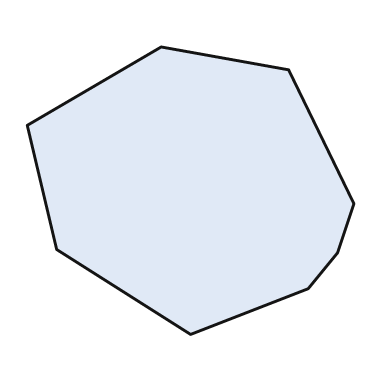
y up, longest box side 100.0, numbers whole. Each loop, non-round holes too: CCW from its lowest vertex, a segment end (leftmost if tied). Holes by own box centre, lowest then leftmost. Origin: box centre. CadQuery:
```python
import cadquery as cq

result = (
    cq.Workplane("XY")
    .moveTo(0.0, -44.0)
    .lineTo(36.0, -30.0)
    .lineTo(45.0, -19.0)
    .lineTo(50.0, -4.0)
    .lineTo(30.0, 37.0)
    .lineTo(-9.0, 44.0)
    .lineTo(-50.0, 20.0)
    .lineTo(-41.0, -18.0)
    .close()
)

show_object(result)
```